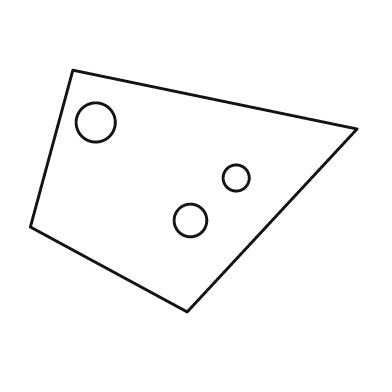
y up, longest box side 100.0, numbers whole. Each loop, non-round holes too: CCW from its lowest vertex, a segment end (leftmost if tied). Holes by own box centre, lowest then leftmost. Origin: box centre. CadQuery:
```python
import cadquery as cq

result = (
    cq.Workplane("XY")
    .moveTo(-2.0, -37.0)
    .lineTo(50.0, 19.0)
    .lineTo(-37.0, 37.0)
    .lineTo(-50.0, -11.0)
    .close()
    .moveTo(-1.0, -9.0)
    .circle(5.0)
    .moveTo(13.0, 4.0)
    .circle(4.0)
    .moveTo(-30.0, 21.0)
    .circle(6.0)
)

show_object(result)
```